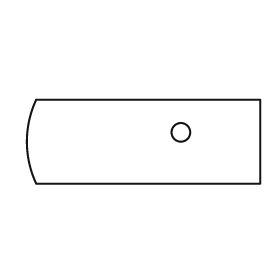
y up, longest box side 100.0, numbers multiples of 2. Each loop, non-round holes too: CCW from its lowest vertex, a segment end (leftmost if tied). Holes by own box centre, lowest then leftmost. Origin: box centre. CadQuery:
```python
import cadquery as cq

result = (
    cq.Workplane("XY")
    .moveTo(-46.0, -18.0)
    .lineTo(50.0, -18.0)
    .lineTo(50.0, 18.0)
    .lineTo(-46.0, 18.0)
    .threePointArc((-50.0, 0.0), (-46.0, -18.0))
    .close()
    .moveTo(16.0, 4.0)
    .circle(4.0)
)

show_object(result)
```